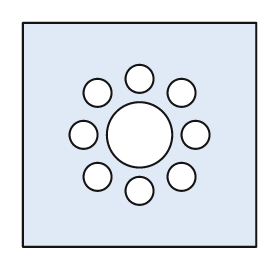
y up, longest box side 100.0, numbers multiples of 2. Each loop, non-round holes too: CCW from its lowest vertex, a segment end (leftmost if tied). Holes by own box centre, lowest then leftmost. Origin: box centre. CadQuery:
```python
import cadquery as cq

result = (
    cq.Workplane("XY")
    .moveTo(-50.0, -48.0)
    .lineTo(50.0, -48.0)
    .lineTo(50.0, 48.0)
    .lineTo(-50.0, 48.0)
    .close()
    .moveTo(0.0, -24.0)
    .circle(6.0)
    .moveTo(-18.0, -18.0)
    .circle(6.0)
    .moveTo(18.0, -18.0)
    .circle(6.0)
    .moveTo(-24.0, 0.0)
    .circle(6.0)
    .moveTo(0.0, 0.0)
    .circle(14.0)
    .moveTo(24.0, 0.0)
    .circle(6.0)
    .moveTo(-18.0, 18.0)
    .circle(6.0)
    .moveTo(18.0, 18.0)
    .circle(6.0)
    .moveTo(0.0, 24.0)
    .circle(6.0)
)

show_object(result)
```